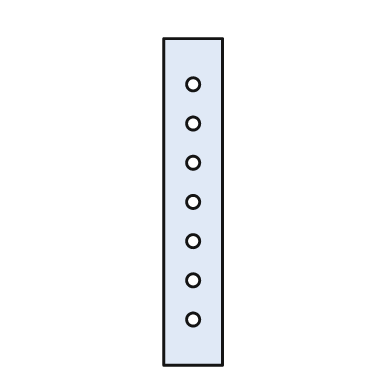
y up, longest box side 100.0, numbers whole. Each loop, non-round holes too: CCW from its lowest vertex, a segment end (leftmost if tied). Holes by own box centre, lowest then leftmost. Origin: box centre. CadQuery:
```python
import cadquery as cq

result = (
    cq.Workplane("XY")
    .moveTo(-9.0, -50.0)
    .lineTo(9.0, -50.0)
    .lineTo(9.0, 50.0)
    .lineTo(-9.0, 50.0)
    .close()
    .moveTo(0.0, -36.0)
    .circle(2.0)
    .moveTo(0.0, -24.0)
    .circle(2.0)
    .moveTo(0.0, -12.0)
    .circle(2.0)
    .moveTo(0.0, 0.0)
    .circle(2.0)
    .moveTo(0.0, 12.0)
    .circle(2.0)
    .moveTo(0.0, 24.0)
    .circle(2.0)
    .moveTo(0.0, 36.0)
    .circle(2.0)
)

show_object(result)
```